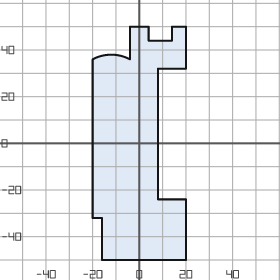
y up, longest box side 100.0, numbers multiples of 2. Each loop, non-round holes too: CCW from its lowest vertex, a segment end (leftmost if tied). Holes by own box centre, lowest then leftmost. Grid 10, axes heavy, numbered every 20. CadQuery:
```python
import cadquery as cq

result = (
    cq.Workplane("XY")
    .moveTo(-16.0, -50.0)
    .lineTo(20.0, -50.0)
    .lineTo(20.0, -24.0)
    .lineTo(8.0, -24.0)
    .lineTo(8.0, 32.0)
    .lineTo(20.0, 32.0)
    .lineTo(20.0, 50.0)
    .lineTo(14.0, 50.0)
    .lineTo(14.0, 44.0)
    .lineTo(4.0, 44.0)
    .lineTo(4.0, 50.0)
    .lineTo(-4.0, 50.0)
    .lineTo(-4.0, 36.0)
    .threePointArc((-12.0, 38.0), (-20.0, 36.0))
    .lineTo(-20.0, -32.0)
    .lineTo(-16.0, -32.0)
    .close()
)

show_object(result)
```